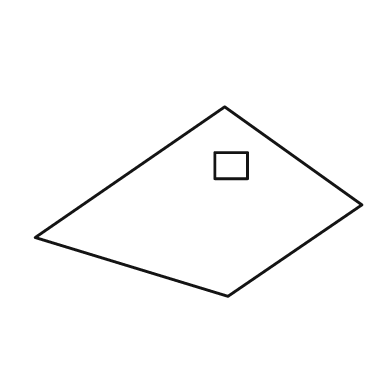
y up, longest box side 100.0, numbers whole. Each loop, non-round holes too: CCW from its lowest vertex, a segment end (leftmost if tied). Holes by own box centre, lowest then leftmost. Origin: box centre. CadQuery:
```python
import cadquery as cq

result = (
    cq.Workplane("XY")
    .moveTo(9.0, -29.0)
    .lineTo(50.0, -1.0)
    .lineTo(8.0, 29.0)
    .lineTo(-50.0, -11.0)
    .close()
    .moveTo(5.0, 7.0)
    .lineTo(15.0, 7.0)
    .lineTo(15.0, 15.0)
    .lineTo(5.0, 15.0)
    .close()
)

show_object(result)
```